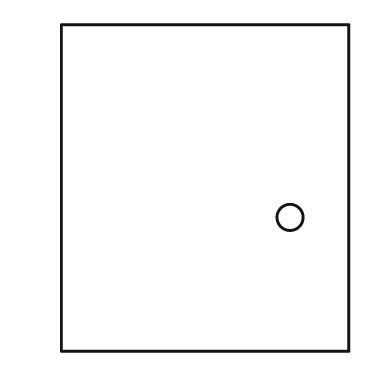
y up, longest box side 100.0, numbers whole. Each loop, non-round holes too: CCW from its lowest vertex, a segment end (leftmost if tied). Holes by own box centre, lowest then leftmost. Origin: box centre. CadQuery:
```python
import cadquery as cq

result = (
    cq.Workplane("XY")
    .moveTo(-44.0, -50.0)
    .lineTo(44.0, -50.0)
    .lineTo(44.0, 50.0)
    .lineTo(-44.0, 50.0)
    .close()
    .moveTo(26.0, -9.0)
    .circle(4.0)
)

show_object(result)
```